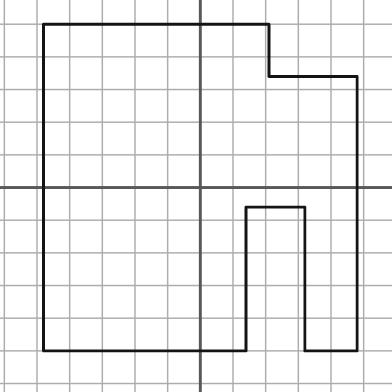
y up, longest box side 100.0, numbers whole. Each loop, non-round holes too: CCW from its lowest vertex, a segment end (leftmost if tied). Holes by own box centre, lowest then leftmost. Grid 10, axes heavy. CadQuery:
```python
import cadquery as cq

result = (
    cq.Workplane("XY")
    .moveTo(-48.0, -50.0)
    .lineTo(14.0, -50.0)
    .lineTo(14.0, -6.0)
    .lineTo(32.0, -6.0)
    .lineTo(32.0, -50.0)
    .lineTo(48.0, -50.0)
    .lineTo(48.0, 34.0)
    .lineTo(21.0, 34.0)
    .lineTo(21.0, 50.0)
    .lineTo(-48.0, 50.0)
    .close()
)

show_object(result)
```